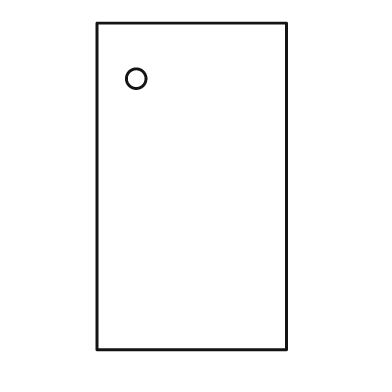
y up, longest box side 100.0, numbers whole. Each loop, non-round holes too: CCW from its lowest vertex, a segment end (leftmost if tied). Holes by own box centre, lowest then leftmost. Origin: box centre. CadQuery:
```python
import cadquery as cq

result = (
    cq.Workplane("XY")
    .moveTo(-29.0, -50.0)
    .lineTo(29.0, -50.0)
    .lineTo(29.0, 50.0)
    .lineTo(-29.0, 50.0)
    .close()
    .moveTo(-17.0, 33.0)
    .circle(3.0)
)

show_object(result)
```